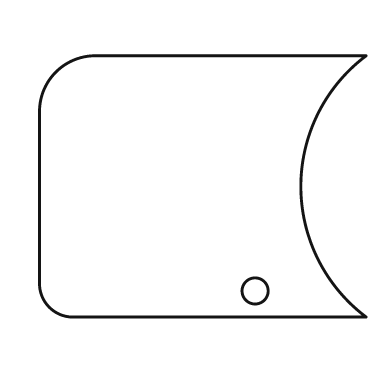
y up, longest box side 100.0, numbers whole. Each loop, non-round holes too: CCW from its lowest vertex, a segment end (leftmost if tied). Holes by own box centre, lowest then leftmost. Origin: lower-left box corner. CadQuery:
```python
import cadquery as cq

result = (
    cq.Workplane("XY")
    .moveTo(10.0, 0.0)
    .lineTo(100.0, 0.0)
    .threePointArc((80.0, 40.0), (100.0, 80.0))
    .lineTo(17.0, 80.0)
    .threePointArc((5.0, 75.0), (0.0, 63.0))
    .lineTo(0.0, 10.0)
    .threePointArc((3.0, 3.0), (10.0, 0.0))
    .close()
    .moveTo(66.0, 8.0)
    .circle(4.0)
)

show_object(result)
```